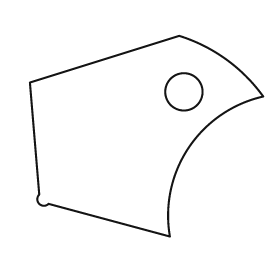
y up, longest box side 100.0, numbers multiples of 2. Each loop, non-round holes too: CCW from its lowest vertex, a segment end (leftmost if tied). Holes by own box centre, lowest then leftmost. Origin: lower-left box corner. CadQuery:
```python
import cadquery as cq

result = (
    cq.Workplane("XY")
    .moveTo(60.0, 0.0)
    .threePointArc((68.0, 38.0), (100.0, 60.0))
    .threePointArc((84.0, 76.0), (64.0, 86.0))
    .lineTo(0.0, 66.0)
    .lineTo(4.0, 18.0)
    .threePointArc((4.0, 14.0), (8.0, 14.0))
    .close()
    .moveTo(66.0, 62.0)
    .circle(8.0)
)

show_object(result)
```